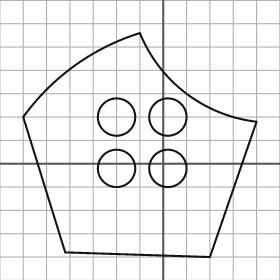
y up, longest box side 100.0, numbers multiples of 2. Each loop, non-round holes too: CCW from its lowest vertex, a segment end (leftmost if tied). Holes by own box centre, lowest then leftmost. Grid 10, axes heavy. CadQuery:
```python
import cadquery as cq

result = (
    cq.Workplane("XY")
    .moveTo(20.0, -40.0)
    .lineTo(40.0, 18.0)
    .threePointArc((10.0, 30.0), (-10.0, 56.0))
    .threePointArc((-38.0, 42.0), (-60.0, 20.0))
    .lineTo(-42.0, -38.0)
    .close()
    .moveTo(-20.0, -2.0)
    .circle(8.0)
    .moveTo(2.0, -2.0)
    .circle(8.0)
    .moveTo(-20.0, 20.0)
    .circle(8.0)
    .moveTo(2.0, 20.0)
    .circle(8.0)
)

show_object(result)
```